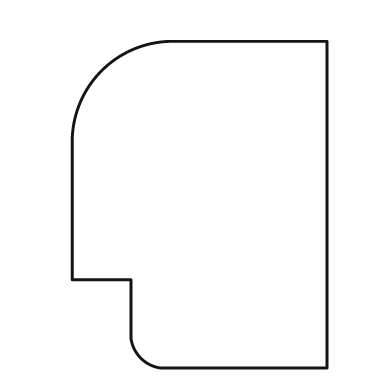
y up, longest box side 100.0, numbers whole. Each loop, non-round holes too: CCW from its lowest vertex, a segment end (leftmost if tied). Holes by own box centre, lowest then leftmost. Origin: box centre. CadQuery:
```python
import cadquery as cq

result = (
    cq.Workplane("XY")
    .moveTo(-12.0, -50.0)
    .lineTo(39.0, -50.0)
    .lineTo(39.0, 50.0)
    .lineTo(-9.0, 50.0)
    .threePointArc((-30.0, 41.0), (-39.0, 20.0))
    .lineTo(-39.0, -23.0)
    .lineTo(-21.0, -23.0)
    .lineTo(-21.0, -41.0)
    .threePointArc((-18.0, -47.0), (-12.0, -50.0))
    .close()
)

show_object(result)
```